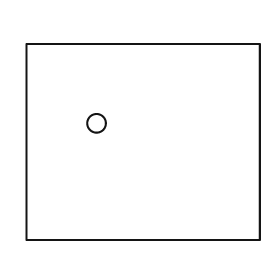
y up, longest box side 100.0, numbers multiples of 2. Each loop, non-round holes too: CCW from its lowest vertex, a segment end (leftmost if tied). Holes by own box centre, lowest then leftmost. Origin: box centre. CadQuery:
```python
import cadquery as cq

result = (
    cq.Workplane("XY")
    .moveTo(-50.0, -42.0)
    .lineTo(50.0, -42.0)
    .lineTo(50.0, 42.0)
    .lineTo(-50.0, 42.0)
    .close()
    .moveTo(-20.0, 8.0)
    .circle(4.0)
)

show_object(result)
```